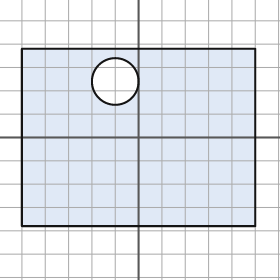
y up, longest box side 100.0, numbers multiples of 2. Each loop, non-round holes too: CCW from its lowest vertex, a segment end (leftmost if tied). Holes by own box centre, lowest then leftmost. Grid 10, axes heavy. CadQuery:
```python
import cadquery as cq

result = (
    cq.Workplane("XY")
    .moveTo(-50.0, -38.0)
    .lineTo(50.0, -38.0)
    .lineTo(50.0, 38.0)
    .lineTo(-50.0, 38.0)
    .close()
    .moveTo(-10.0, 24.0)
    .circle(10.0)
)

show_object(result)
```